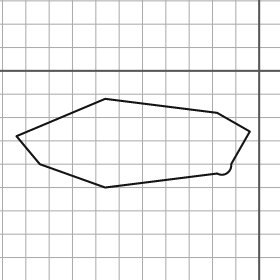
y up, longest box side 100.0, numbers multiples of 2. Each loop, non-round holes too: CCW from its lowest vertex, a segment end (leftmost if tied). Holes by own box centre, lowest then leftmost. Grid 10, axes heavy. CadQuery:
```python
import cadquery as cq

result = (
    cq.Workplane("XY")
    .moveTo(-66.0, -50.0)
    .lineTo(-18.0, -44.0)
    .threePointArc((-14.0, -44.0), (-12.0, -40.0))
    .lineTo(-4.0, -26.0)
    .lineTo(-18.0, -18.0)
    .lineTo(-66.0, -12.0)
    .lineTo(-104.0, -28.0)
    .lineTo(-94.0, -40.0)
    .close()
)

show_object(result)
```